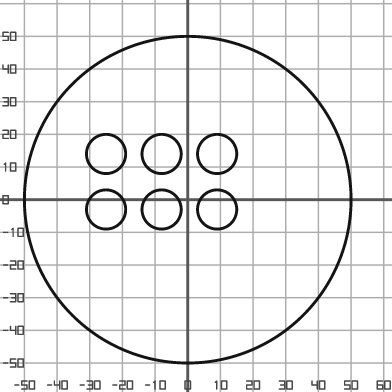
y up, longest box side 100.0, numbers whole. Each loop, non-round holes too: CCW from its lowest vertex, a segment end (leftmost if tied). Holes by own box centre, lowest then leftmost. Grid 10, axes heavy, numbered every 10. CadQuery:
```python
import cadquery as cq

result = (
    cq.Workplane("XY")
    .moveTo(0.0, 0.0)
    .circle(50.0)
    .moveTo(-25.0, -3.0)
    .circle(6.0)
    .moveTo(-8.0, -3.0)
    .circle(6.0)
    .moveTo(9.0, -3.0)
    .circle(6.0)
    .moveTo(-25.0, 14.0)
    .circle(6.0)
    .moveTo(-8.0, 14.0)
    .circle(6.0)
    .moveTo(9.0, 14.0)
    .circle(6.0)
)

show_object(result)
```